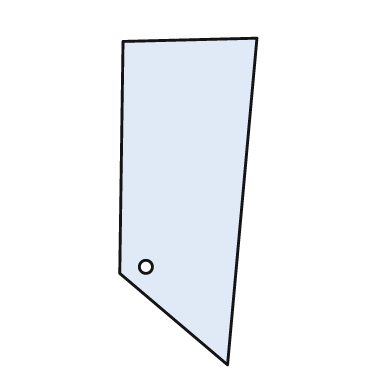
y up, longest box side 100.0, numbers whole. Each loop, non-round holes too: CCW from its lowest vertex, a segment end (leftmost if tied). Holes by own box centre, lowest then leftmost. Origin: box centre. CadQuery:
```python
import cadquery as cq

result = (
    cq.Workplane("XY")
    .moveTo(12.0, -50.0)
    .lineTo(21.0, 50.0)
    .lineTo(-20.0, 49.0)
    .lineTo(-21.0, -22.0)
    .close()
    .moveTo(-13.0, -20.0)
    .circle(2.0)
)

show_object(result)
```